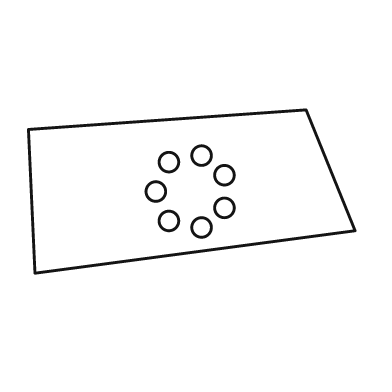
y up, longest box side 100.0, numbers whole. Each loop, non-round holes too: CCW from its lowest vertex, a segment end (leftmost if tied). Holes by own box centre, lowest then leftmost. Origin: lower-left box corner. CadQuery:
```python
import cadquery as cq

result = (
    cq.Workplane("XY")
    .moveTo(2.0, 0.0)
    .lineTo(100.0, 13.0)
    .lineTo(85.0, 50.0)
    .lineTo(0.0, 44.0)
    .close()
    .moveTo(53.0, 14.0)
    .circle(3.0)
    .moveTo(43.0, 16.0)
    .circle(3.0)
    .moveTo(60.0, 20.0)
    .circle(3.0)
    .moveTo(39.0, 25.0)
    .circle(3.0)
    .moveTo(60.0, 30.0)
    .circle(3.0)
    .moveTo(43.0, 34.0)
    .circle(3.0)
    .moveTo(53.0, 36.0)
    .circle(3.0)
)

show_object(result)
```